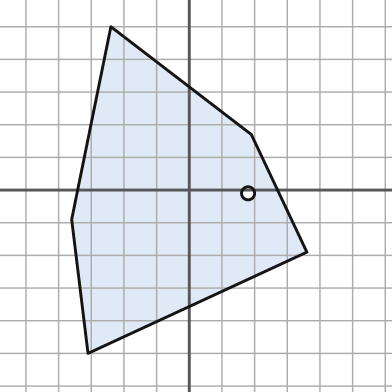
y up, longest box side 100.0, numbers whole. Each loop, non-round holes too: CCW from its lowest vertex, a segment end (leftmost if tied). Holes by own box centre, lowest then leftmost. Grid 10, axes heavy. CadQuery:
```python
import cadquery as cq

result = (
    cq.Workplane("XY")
    .moveTo(-31.0, -50.0)
    .lineTo(36.0, -19.0)
    .lineTo(19.0, 17.0)
    .lineTo(-24.0, 50.0)
    .lineTo(-36.0, -9.0)
    .close()
    .moveTo(18.0, -1.0)
    .circle(2.0)
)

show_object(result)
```